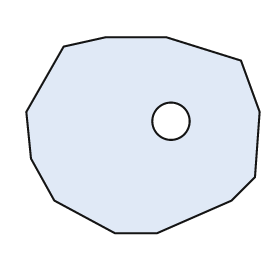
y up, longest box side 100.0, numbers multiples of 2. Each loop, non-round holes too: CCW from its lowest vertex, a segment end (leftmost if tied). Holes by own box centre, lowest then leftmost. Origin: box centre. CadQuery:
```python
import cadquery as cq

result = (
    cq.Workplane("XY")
    .moveTo(-12.0, -42.0)
    .lineTo(6.0, -42.0)
    .lineTo(38.0, -28.0)
    .lineTo(48.0, -18.0)
    .lineTo(50.0, 10.0)
    .lineTo(42.0, 32.0)
    .lineTo(10.0, 42.0)
    .lineTo(-16.0, 42.0)
    .lineTo(-34.0, 38.0)
    .lineTo(-50.0, 10.0)
    .lineTo(-48.0, -10.0)
    .lineTo(-38.0, -28.0)
    .close()
    .moveTo(12.0, 6.0)
    .circle(8.0)
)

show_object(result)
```